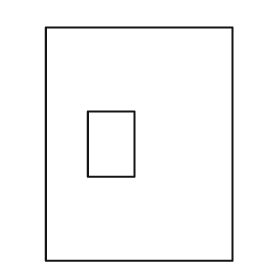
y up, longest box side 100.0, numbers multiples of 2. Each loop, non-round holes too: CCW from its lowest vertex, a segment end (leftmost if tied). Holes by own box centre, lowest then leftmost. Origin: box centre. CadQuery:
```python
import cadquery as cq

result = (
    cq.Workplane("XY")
    .moveTo(-40.0, -50.0)
    .lineTo(40.0, -50.0)
    .lineTo(40.0, 50.0)
    .lineTo(-40.0, 50.0)
    .close()
    .moveTo(-22.0, -14.0)
    .lineTo(-2.0, -14.0)
    .lineTo(-2.0, 14.0)
    .lineTo(-22.0, 14.0)
    .close()
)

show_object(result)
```